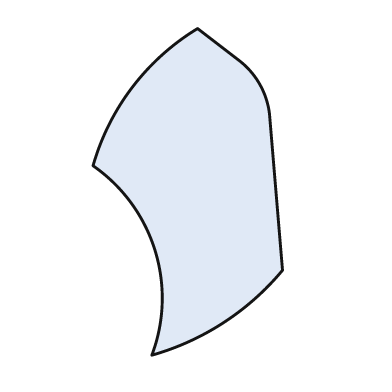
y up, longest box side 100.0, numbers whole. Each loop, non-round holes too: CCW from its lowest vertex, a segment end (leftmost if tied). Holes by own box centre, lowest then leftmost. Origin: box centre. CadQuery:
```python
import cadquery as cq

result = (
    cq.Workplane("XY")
    .moveTo(-11.0, -50.0)
    .threePointArc((11.0, -40.0), (29.0, -24.0))
    .lineTo(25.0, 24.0)
    .threePointArc((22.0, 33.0), (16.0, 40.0))
    .lineTo(3.0, 50.0)
    .threePointArc((-17.0, 32.0), (-29.0, 8.0))
    .threePointArc((-10.0, -18.0), (-11.0, -50.0))
    .close()
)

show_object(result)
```